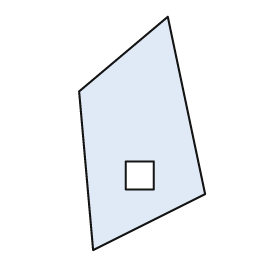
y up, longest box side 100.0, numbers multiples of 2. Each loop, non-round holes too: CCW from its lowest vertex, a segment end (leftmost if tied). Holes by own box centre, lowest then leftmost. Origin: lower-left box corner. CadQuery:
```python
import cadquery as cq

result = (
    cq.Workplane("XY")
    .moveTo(6.0, 0.0)
    .lineTo(54.0, 24.0)
    .lineTo(38.0, 100.0)
    .lineTo(0.0, 68.0)
    .close()
    .moveTo(20.0, 26.0)
    .lineTo(32.0, 26.0)
    .lineTo(32.0, 38.0)
    .lineTo(20.0, 38.0)
    .close()
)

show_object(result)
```